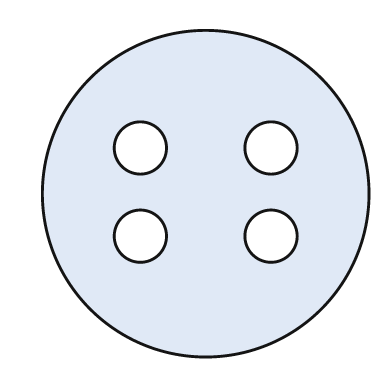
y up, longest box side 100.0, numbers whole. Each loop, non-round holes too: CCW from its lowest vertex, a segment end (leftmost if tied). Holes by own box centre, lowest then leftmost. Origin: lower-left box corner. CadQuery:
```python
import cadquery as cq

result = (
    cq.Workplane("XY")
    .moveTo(50.0, 50.0)
    .circle(50.0)
    .moveTo(30.0, 37.0)
    .circle(8.0)
    .moveTo(70.0, 37.0)
    .circle(8.0)
    .moveTo(30.0, 64.0)
    .circle(8.0)
    .moveTo(70.0, 64.0)
    .circle(8.0)
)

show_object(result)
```